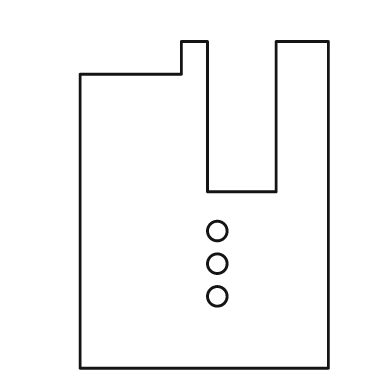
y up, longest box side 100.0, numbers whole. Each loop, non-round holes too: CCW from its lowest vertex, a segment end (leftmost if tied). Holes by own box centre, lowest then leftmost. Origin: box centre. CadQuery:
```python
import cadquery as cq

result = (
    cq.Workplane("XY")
    .moveTo(-38.0, -50.0)
    .lineTo(38.0, -50.0)
    .lineTo(38.0, 50.0)
    .lineTo(22.0, 50.0)
    .lineTo(22.0, 4.0)
    .lineTo(1.0, 4.0)
    .lineTo(1.0, 50.0)
    .lineTo(-7.0, 50.0)
    .lineTo(-7.0, 40.0)
    .lineTo(-38.0, 40.0)
    .close()
    .moveTo(4.0, -28.0)
    .circle(3.0)
    .moveTo(4.0, -18.0)
    .circle(3.0)
    .moveTo(4.0, -8.0)
    .circle(3.0)
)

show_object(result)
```